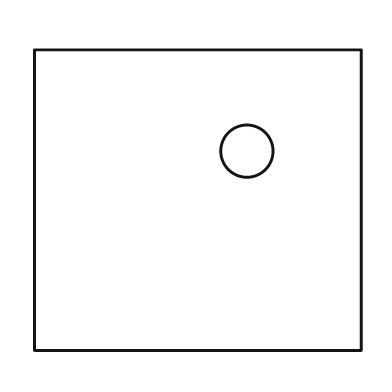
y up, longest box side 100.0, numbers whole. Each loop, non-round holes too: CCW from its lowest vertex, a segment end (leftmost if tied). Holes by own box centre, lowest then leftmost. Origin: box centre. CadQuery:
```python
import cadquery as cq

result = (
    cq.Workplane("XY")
    .moveTo(-50.0, -46.0)
    .lineTo(50.0, -46.0)
    .lineTo(50.0, 46.0)
    .lineTo(-50.0, 46.0)
    .close()
    .moveTo(15.0, 15.0)
    .circle(8.0)
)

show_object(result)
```